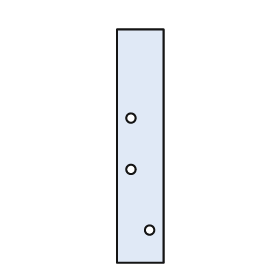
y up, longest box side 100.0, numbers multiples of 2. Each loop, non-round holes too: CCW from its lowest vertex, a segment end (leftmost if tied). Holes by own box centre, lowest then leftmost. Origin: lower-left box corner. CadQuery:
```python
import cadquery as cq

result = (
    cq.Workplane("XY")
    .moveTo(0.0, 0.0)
    .lineTo(20.0, 0.0)
    .lineTo(20.0, 100.0)
    .lineTo(0.0, 100.0)
    .close()
    .moveTo(14.0, 14.0)
    .circle(2.0)
    .moveTo(6.0, 40.0)
    .circle(2.0)
    .moveTo(6.0, 62.0)
    .circle(2.0)
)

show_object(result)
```